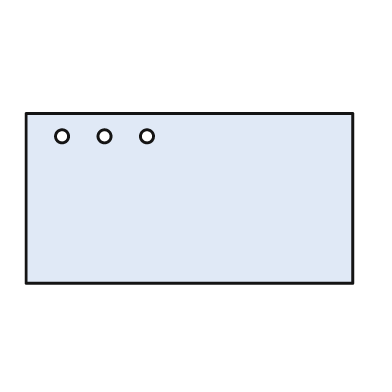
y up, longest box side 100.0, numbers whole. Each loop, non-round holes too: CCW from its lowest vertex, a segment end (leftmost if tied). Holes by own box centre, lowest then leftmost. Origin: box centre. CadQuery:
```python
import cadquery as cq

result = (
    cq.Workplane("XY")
    .moveTo(-50.0, -26.0)
    .lineTo(50.0, -26.0)
    .lineTo(50.0, 26.0)
    .lineTo(-50.0, 26.0)
    .close()
    .moveTo(-39.0, 19.0)
    .circle(2.0)
    .moveTo(-26.0, 19.0)
    .circle(2.0)
    .moveTo(-13.0, 19.0)
    .circle(2.0)
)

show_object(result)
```